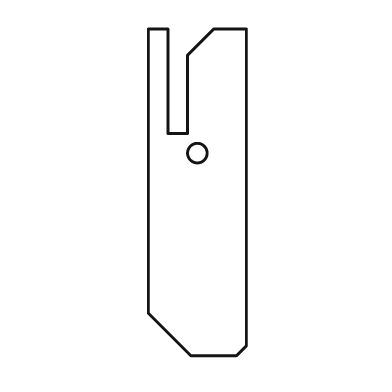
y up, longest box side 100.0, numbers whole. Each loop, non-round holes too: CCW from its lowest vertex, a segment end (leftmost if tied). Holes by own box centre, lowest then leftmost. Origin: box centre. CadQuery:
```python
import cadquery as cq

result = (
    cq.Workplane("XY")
    .moveTo(-2.0, -50.0)
    .lineTo(12.0, -50.0)
    .lineTo(15.0, -47.0)
    .lineTo(15.0, 50.0)
    .lineTo(5.0, 50.0)
    .lineTo(-3.0, 42.0)
    .lineTo(-3.0, 18.0)
    .lineTo(-9.0, 18.0)
    .lineTo(-9.0, 50.0)
    .lineTo(-15.0, 50.0)
    .lineTo(-15.0, -37.0)
    .close()
    .moveTo(0.0, 12.0)
    .circle(3.0)
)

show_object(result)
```